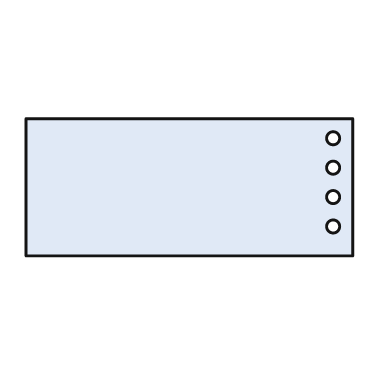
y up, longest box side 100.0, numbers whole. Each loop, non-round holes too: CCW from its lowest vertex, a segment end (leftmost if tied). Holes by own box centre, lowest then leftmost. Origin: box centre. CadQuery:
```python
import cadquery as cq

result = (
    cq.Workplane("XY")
    .moveTo(-50.0, -21.0)
    .lineTo(50.0, -21.0)
    .lineTo(50.0, 21.0)
    .lineTo(-50.0, 21.0)
    .close()
    .moveTo(44.0, -12.0)
    .circle(2.0)
    .moveTo(44.0, -3.0)
    .circle(2.0)
    .moveTo(44.0, 6.0)
    .circle(2.0)
    .moveTo(44.0, 15.0)
    .circle(2.0)
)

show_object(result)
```